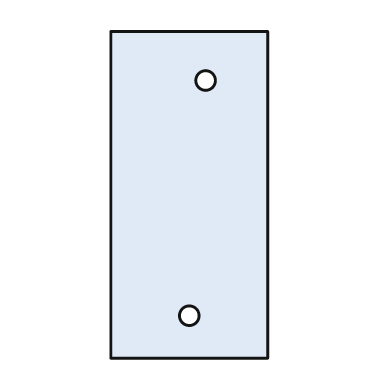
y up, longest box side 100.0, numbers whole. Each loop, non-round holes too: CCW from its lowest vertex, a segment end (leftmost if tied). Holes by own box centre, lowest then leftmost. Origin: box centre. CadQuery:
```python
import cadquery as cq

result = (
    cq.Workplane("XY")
    .moveTo(-24.0, -50.0)
    .lineTo(24.0, -50.0)
    .lineTo(24.0, 50.0)
    .lineTo(-24.0, 50.0)
    .close()
    .moveTo(0.0, -37.0)
    .circle(3.0)
    .moveTo(5.0, 35.0)
    .circle(3.0)
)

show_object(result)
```